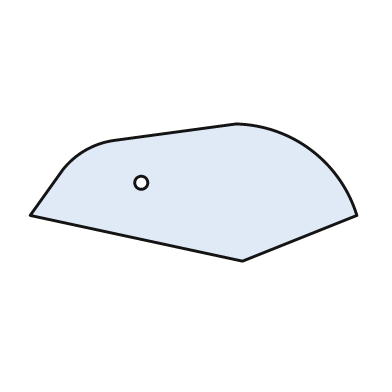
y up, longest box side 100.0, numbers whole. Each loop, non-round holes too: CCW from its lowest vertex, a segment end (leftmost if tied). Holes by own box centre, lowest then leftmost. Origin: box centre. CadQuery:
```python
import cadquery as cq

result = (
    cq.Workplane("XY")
    .moveTo(15.0, -21.0)
    .lineTo(50.0, -7.0)
    .threePointArc((36.0, 13.0), (13.0, 21.0))
    .lineTo(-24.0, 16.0)
    .threePointArc((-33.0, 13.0), (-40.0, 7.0))
    .lineTo(-50.0, -7.0)
    .close()
    .moveTo(-16.0, 3.0)
    .circle(2.0)
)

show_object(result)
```